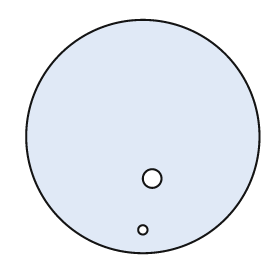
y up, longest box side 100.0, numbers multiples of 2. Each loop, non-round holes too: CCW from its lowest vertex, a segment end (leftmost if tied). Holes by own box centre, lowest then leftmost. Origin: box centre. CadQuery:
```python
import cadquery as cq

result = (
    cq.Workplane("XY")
    .moveTo(0.0, 0.0)
    .circle(50.0)
    .moveTo(0.0, -40.0)
    .circle(2.0)
    .moveTo(4.0, -18.0)
    .circle(4.0)
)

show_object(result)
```